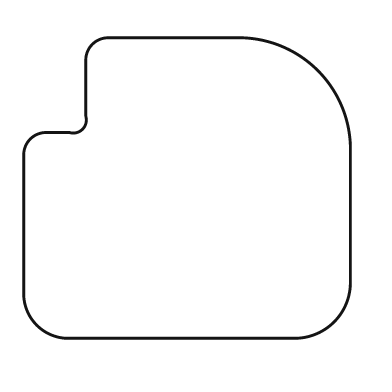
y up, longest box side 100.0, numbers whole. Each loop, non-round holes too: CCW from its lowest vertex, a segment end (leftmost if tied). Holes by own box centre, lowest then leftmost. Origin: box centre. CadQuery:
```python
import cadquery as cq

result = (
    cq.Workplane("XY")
    .moveTo(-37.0, -46.0)
    .lineTo(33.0, -46.0)
    .threePointArc((45.0, -41.0), (50.0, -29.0))
    .lineTo(50.0, 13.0)
    .threePointArc((40.0, 36.0), (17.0, 46.0))
    .lineTo(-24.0, 46.0)
    .threePointArc((-29.0, 44.0), (-31.0, 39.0))
    .lineTo(-31.0, 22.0)
    .threePointArc((-32.0, 18.0), (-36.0, 17.0))
    .lineTo(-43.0, 17.0)
    .threePointArc((-48.0, 15.0), (-50.0, 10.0))
    .lineTo(-50.0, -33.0)
    .threePointArc((-46.0, -42.0), (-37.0, -46.0))
    .close()
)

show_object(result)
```